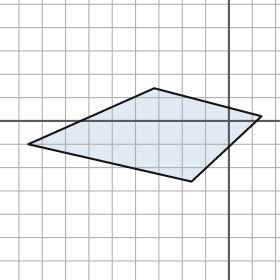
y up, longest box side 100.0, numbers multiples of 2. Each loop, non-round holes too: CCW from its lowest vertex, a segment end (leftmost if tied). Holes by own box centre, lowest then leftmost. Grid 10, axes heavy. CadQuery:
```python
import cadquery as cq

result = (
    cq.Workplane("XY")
    .moveTo(-16.0, -26.0)
    .lineTo(14.0, 2.0)
    .lineTo(-32.0, 14.0)
    .lineTo(-86.0, -10.0)
    .close()
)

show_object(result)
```